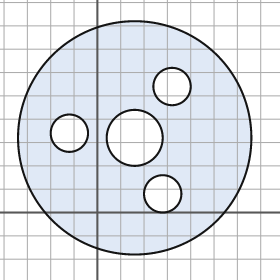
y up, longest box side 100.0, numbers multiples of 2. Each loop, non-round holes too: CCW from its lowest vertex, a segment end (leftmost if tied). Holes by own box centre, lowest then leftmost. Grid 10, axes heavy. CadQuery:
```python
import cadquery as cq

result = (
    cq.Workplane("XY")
    .moveTo(16.0, 32.0)
    .circle(50.0)
    .moveTo(28.0, 8.0)
    .circle(8.0)
    .moveTo(16.0, 32.0)
    .circle(12.0)
    .moveTo(-12.0, 34.0)
    .circle(8.0)
    .moveTo(32.0, 54.0)
    .circle(8.0)
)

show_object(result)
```